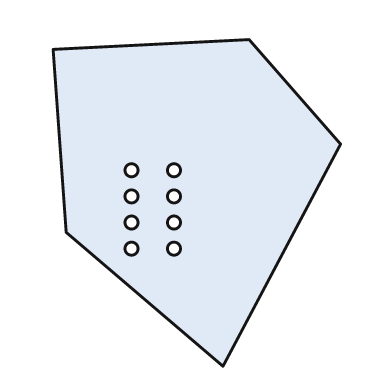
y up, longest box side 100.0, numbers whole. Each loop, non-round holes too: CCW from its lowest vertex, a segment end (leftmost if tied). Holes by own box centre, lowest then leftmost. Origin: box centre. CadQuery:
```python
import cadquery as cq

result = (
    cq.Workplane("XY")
    .moveTo(8.0, -50.0)
    .lineTo(44.0, 18.0)
    .lineTo(16.0, 50.0)
    .lineTo(-44.0, 47.0)
    .lineTo(-40.0, -9.0)
    .close()
    .moveTo(-20.0, -14.0)
    .circle(2.0)
    .moveTo(-7.0, -14.0)
    .circle(2.0)
    .moveTo(-20.0, -6.0)
    .circle(2.0)
    .moveTo(-7.0, -6.0)
    .circle(2.0)
    .moveTo(-20.0, 2.0)
    .circle(2.0)
    .moveTo(-7.0, 2.0)
    .circle(2.0)
    .moveTo(-20.0, 10.0)
    .circle(2.0)
    .moveTo(-7.0, 10.0)
    .circle(2.0)
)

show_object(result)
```